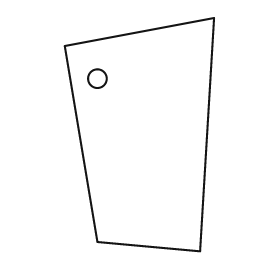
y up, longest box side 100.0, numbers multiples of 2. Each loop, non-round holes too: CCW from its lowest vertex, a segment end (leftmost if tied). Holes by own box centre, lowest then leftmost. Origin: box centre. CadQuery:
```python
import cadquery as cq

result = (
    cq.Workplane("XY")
    .moveTo(26.0, -50.0)
    .lineTo(32.0, 50.0)
    .lineTo(-32.0, 38.0)
    .lineTo(-18.0, -46.0)
    .close()
    .moveTo(-18.0, 24.0)
    .circle(4.0)
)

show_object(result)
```